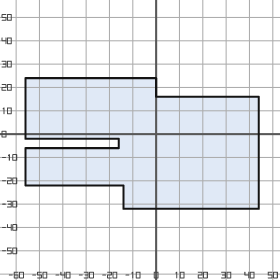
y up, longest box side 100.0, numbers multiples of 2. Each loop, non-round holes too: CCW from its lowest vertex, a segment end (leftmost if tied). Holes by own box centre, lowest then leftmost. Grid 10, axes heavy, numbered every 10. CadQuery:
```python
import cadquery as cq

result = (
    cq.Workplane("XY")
    .moveTo(-14.0, -32.0)
    .lineTo(44.0, -32.0)
    .lineTo(44.0, 16.0)
    .lineTo(0.0, 16.0)
    .lineTo(0.0, 24.0)
    .lineTo(-56.0, 24.0)
    .lineTo(-56.0, -2.0)
    .lineTo(-16.0, -2.0)
    .lineTo(-16.0, -6.0)
    .lineTo(-56.0, -6.0)
    .lineTo(-56.0, -22.0)
    .lineTo(-14.0, -22.0)
    .close()
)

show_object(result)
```